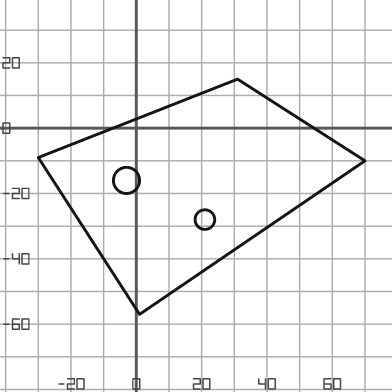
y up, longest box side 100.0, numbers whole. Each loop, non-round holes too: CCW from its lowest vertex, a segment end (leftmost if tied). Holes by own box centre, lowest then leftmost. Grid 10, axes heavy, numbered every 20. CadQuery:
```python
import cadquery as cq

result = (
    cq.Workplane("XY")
    .moveTo(1.0, -57.0)
    .lineTo(70.0, -10.0)
    .lineTo(31.0, 15.0)
    .lineTo(-30.0, -9.0)
    .close()
    .moveTo(21.0, -28.0)
    .circle(3.0)
    .moveTo(-3.0, -16.0)
    .circle(4.0)
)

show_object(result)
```